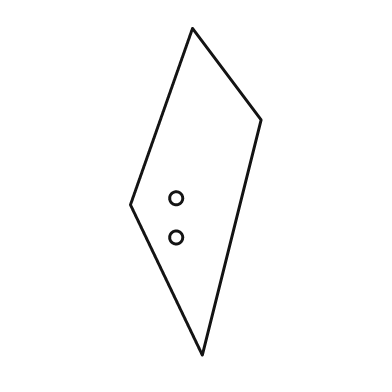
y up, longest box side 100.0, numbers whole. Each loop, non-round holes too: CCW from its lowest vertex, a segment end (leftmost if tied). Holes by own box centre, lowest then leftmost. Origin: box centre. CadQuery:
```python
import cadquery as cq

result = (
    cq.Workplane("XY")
    .moveTo(2.0, -50.0)
    .lineTo(20.0, 22.0)
    .lineTo(-1.0, 50.0)
    .lineTo(-20.0, -4.0)
    .close()
    .moveTo(-6.0, -14.0)
    .circle(2.0)
    .moveTo(-6.0, -2.0)
    .circle(2.0)
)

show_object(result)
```